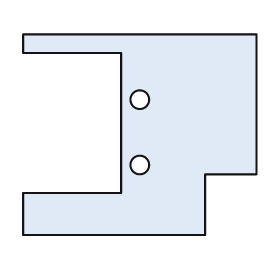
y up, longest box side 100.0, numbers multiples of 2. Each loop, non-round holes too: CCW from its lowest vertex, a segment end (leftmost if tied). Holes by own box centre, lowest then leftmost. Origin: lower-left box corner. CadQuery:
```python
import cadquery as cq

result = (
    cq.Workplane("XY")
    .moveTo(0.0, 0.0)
    .lineTo(78.0, 0.0)
    .lineTo(78.0, 26.0)
    .lineTo(100.0, 26.0)
    .lineTo(100.0, 86.0)
    .lineTo(0.0, 86.0)
    .lineTo(0.0, 78.0)
    .lineTo(42.0, 78.0)
    .lineTo(42.0, 18.0)
    .lineTo(0.0, 18.0)
    .close()
    .moveTo(50.0, 30.0)
    .circle(4.0)
    .moveTo(50.0, 58.0)
    .circle(4.0)
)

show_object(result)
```